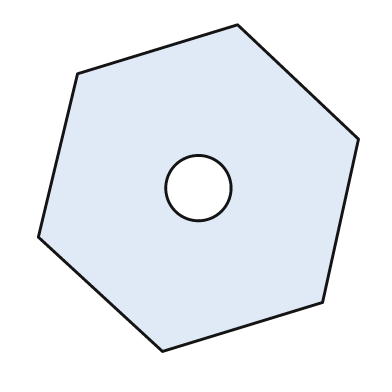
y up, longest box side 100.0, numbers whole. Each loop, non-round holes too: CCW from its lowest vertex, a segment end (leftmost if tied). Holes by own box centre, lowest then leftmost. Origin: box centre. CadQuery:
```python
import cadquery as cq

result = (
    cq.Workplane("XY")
    .moveTo(-11.0, -50.0)
    .lineTo(38.0, -35.0)
    .lineTo(49.0, 15.0)
    .lineTo(12.0, 50.0)
    .lineTo(-37.0, 35.0)
    .lineTo(-49.0, -15.0)
    .close()
    .moveTo(0.0, 0.0)
    .circle(10.0)
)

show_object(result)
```